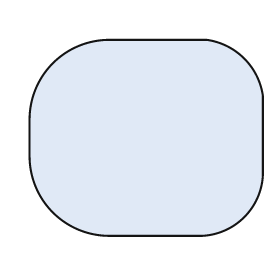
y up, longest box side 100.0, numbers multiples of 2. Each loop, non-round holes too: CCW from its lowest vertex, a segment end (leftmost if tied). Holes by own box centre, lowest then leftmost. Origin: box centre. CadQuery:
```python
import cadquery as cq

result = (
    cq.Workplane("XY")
    .moveTo(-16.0, -42.0)
    .lineTo(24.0, -42.0)
    .threePointArc((42.0, -34.0), (50.0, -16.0))
    .lineTo(50.0, 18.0)
    .threePointArc((42.0, 34.0), (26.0, 42.0))
    .lineTo(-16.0, 42.0)
    .threePointArc((-40.0, 32.0), (-50.0, 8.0))
    .lineTo(-50.0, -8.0)
    .threePointArc((-40.0, -32.0), (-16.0, -42.0))
    .close()
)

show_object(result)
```